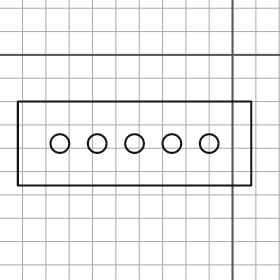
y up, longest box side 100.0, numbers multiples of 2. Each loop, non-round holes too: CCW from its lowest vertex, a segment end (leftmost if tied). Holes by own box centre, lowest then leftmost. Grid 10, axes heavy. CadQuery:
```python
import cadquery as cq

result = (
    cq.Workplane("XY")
    .moveTo(-92.0, -56.0)
    .lineTo(8.0, -56.0)
    .lineTo(8.0, -20.0)
    .lineTo(-92.0, -20.0)
    .close()
    .moveTo(-74.0, -38.0)
    .circle(4.0)
    .moveTo(-58.0, -38.0)
    .circle(4.0)
    .moveTo(-42.0, -38.0)
    .circle(4.0)
    .moveTo(-26.0, -38.0)
    .circle(4.0)
    .moveTo(-10.0, -38.0)
    .circle(4.0)
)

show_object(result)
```